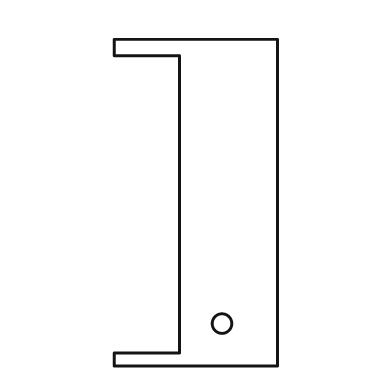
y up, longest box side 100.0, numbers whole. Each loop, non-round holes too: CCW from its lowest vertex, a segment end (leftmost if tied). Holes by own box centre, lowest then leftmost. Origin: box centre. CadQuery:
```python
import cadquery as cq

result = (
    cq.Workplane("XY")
    .moveTo(-25.0, -50.0)
    .lineTo(25.0, -50.0)
    .lineTo(25.0, 50.0)
    .lineTo(-25.0, 50.0)
    .lineTo(-25.0, 45.0)
    .lineTo(-5.0, 45.0)
    .lineTo(-5.0, -46.0)
    .lineTo(-25.0, -46.0)
    .close()
    .moveTo(8.0, -37.0)
    .circle(3.0)
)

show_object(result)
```